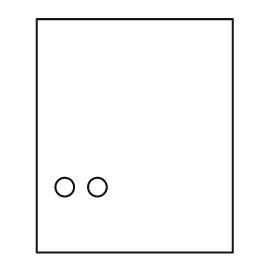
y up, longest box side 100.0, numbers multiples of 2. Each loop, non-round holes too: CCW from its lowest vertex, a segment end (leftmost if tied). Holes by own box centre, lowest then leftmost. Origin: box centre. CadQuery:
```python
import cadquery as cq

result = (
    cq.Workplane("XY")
    .moveTo(-42.0, -50.0)
    .lineTo(42.0, -50.0)
    .lineTo(42.0, 50.0)
    .lineTo(-42.0, 50.0)
    .close()
    .moveTo(-30.0, -22.0)
    .circle(4.0)
    .moveTo(-16.0, -22.0)
    .circle(4.0)
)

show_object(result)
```